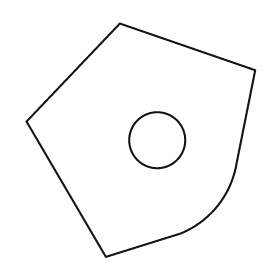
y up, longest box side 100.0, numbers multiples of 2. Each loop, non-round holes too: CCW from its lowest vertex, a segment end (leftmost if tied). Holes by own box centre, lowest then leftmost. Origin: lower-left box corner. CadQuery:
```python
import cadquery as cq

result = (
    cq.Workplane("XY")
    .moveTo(34.0, 0.0)
    .lineTo(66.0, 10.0)
    .threePointArc((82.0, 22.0), (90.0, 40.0))
    .lineTo(98.0, 80.0)
    .lineTo(40.0, 100.0)
    .lineTo(0.0, 58.0)
    .close()
    .moveTo(56.0, 50.0)
    .circle(12.0)
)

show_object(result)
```